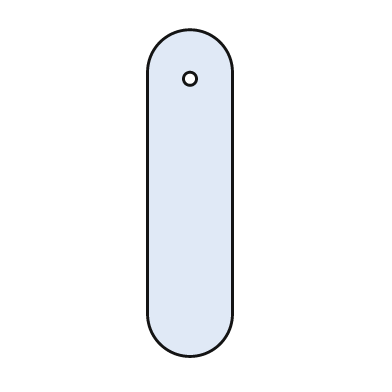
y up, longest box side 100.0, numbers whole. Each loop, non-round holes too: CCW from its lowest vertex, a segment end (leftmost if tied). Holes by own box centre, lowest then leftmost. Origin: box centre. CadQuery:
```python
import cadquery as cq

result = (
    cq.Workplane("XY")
    .moveTo(-13.0, -37.0)
    .threePointArc((0.0, -50.0), (13.0, -37.0))
    .lineTo(13.0, 37.0)
    .threePointArc((0.0, 50.0), (-13.0, 37.0))
    .close()
    .moveTo(0.0, 35.0)
    .circle(2.0)
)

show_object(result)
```